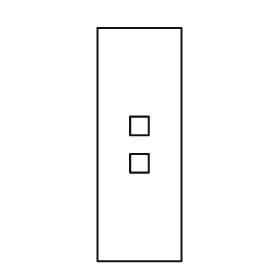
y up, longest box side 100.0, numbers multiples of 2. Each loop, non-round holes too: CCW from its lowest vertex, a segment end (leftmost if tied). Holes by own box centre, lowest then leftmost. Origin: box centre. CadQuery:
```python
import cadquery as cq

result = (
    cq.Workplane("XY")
    .moveTo(-18.0, -50.0)
    .lineTo(18.0, -50.0)
    .lineTo(18.0, 50.0)
    .lineTo(-18.0, 50.0)
    .close()
    .moveTo(-4.0, -12.0)
    .lineTo(4.0, -12.0)
    .lineTo(4.0, -4.0)
    .lineTo(-4.0, -4.0)
    .close()
    .moveTo(-4.0, 4.0)
    .lineTo(4.0, 4.0)
    .lineTo(4.0, 12.0)
    .lineTo(-4.0, 12.0)
    .close()
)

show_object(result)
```